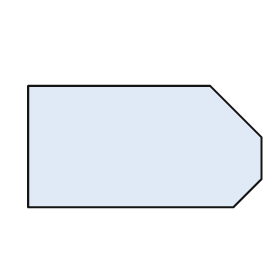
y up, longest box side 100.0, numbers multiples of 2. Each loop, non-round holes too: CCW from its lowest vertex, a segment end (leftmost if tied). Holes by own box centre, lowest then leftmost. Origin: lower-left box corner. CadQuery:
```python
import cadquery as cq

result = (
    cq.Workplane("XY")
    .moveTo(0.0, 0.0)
    .lineTo(88.0, 0.0)
    .lineTo(100.0, 12.0)
    .lineTo(100.0, 30.0)
    .lineTo(78.0, 52.0)
    .lineTo(0.0, 52.0)
    .close()
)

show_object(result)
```